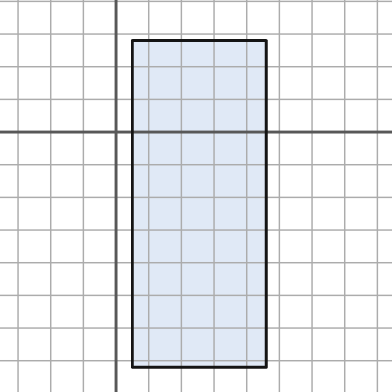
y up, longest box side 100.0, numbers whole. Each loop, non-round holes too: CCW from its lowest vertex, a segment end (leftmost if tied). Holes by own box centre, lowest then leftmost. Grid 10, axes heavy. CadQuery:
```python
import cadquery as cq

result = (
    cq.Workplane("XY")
    .moveTo(5.0, -72.0)
    .lineTo(46.0, -72.0)
    .lineTo(46.0, 28.0)
    .lineTo(5.0, 28.0)
    .close()
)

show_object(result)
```